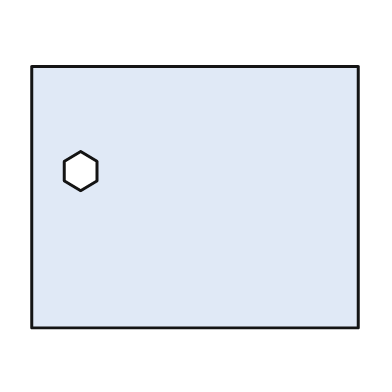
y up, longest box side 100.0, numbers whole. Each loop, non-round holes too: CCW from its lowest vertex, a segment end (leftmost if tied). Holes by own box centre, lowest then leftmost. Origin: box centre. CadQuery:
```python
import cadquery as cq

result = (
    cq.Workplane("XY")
    .moveTo(-50.0, -40.0)
    .lineTo(50.0, -40.0)
    .lineTo(50.0, 40.0)
    .lineTo(-50.0, 40.0)
    .close()
    .moveTo(-35.0, 2.0)
    .lineTo(-30.0, 5.0)
    .lineTo(-30.0, 11.0)
    .lineTo(-35.0, 14.0)
    .lineTo(-40.0, 11.0)
    .lineTo(-40.0, 5.0)
    .close()
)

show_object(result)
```